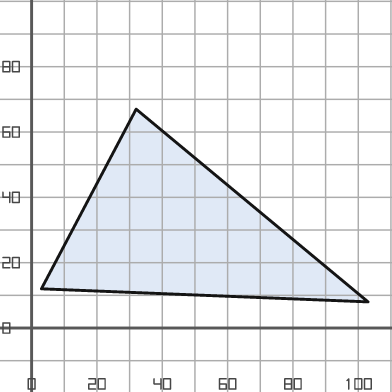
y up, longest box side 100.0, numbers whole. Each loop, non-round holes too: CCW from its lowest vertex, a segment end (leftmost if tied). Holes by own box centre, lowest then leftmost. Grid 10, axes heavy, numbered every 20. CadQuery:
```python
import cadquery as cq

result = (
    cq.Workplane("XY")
    .moveTo(103.0, 8.0)
    .lineTo(32.0, 67.0)
    .lineTo(3.0, 12.0)
    .close()
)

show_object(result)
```